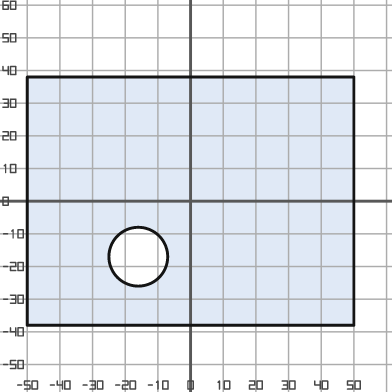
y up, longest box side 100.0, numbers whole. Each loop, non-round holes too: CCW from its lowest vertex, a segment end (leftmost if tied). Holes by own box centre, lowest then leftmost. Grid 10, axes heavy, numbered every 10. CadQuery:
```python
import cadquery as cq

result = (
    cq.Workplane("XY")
    .moveTo(-50.0, -38.0)
    .lineTo(50.0, -38.0)
    .lineTo(50.0, 38.0)
    .lineTo(-50.0, 38.0)
    .close()
    .moveTo(-16.0, -17.0)
    .circle(9.0)
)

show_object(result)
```